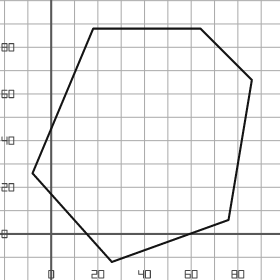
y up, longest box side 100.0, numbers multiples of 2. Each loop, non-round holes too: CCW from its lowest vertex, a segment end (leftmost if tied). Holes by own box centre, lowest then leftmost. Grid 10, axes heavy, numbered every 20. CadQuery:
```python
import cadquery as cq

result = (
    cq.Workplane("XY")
    .moveTo(26.0, -12.0)
    .lineTo(76.0, 6.0)
    .lineTo(86.0, 66.0)
    .lineTo(64.0, 88.0)
    .lineTo(18.0, 88.0)
    .lineTo(-8.0, 26.0)
    .close()
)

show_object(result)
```